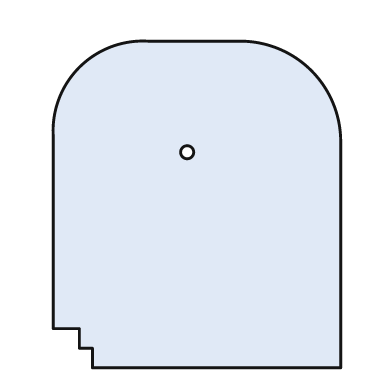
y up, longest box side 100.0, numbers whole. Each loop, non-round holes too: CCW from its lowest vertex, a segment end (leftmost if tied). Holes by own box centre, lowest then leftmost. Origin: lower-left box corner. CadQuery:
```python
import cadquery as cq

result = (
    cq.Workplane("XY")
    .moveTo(12.0, 0.0)
    .lineTo(88.0, 0.0)
    .lineTo(88.0, 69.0)
    .threePointArc((79.0, 91.0), (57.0, 100.0))
    .lineTo(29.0, 100.0)
    .threePointArc((8.0, 92.0), (0.0, 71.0))
    .lineTo(0.0, 12.0)
    .lineTo(8.0, 12.0)
    .lineTo(8.0, 6.0)
    .lineTo(12.0, 6.0)
    .close()
    .moveTo(41.0, 66.0)
    .circle(2.0)
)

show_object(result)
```